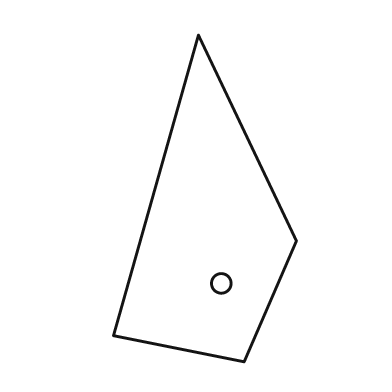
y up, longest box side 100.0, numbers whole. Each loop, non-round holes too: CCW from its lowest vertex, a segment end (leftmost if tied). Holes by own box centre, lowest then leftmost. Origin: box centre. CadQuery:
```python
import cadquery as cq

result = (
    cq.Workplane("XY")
    .moveTo(12.0, -50.0)
    .lineTo(28.0, -13.0)
    .lineTo(-2.0, 50.0)
    .lineTo(-28.0, -42.0)
    .close()
    .moveTo(5.0, -26.0)
    .circle(3.0)
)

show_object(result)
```